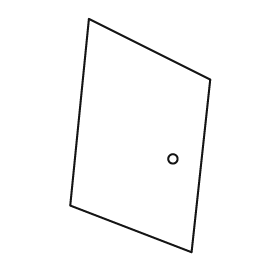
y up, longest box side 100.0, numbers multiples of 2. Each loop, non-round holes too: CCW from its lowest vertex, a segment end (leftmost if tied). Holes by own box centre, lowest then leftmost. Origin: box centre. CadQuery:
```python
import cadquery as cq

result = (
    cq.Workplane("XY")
    .moveTo(22.0, -50.0)
    .lineTo(30.0, 24.0)
    .lineTo(-22.0, 50.0)
    .lineTo(-30.0, -30.0)
    .close()
    .moveTo(14.0, -10.0)
    .circle(2.0)
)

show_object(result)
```